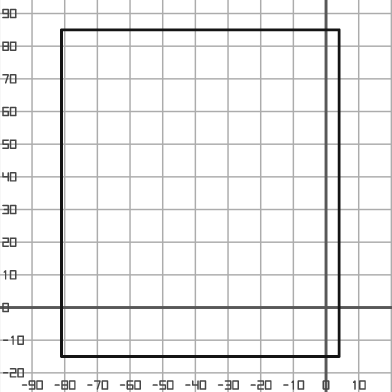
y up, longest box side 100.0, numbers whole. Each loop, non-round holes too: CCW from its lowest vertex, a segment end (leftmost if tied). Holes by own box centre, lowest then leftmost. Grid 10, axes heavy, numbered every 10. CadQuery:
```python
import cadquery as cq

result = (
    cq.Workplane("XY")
    .moveTo(-81.0, -15.0)
    .lineTo(4.0, -15.0)
    .lineTo(4.0, 85.0)
    .lineTo(-81.0, 85.0)
    .close()
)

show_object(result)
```